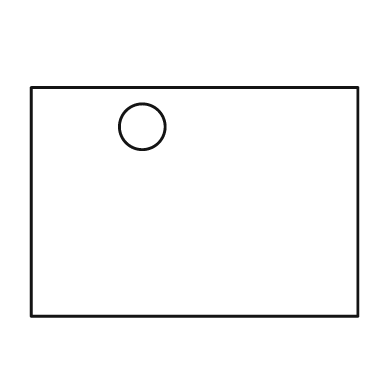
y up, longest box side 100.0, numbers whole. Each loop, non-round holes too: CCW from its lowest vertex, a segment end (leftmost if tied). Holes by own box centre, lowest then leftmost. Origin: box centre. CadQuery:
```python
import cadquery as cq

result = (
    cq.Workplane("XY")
    .moveTo(-50.0, -35.0)
    .lineTo(50.0, -35.0)
    .lineTo(50.0, 35.0)
    .lineTo(-50.0, 35.0)
    .close()
    .moveTo(-16.0, 23.0)
    .circle(7.0)
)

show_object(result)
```